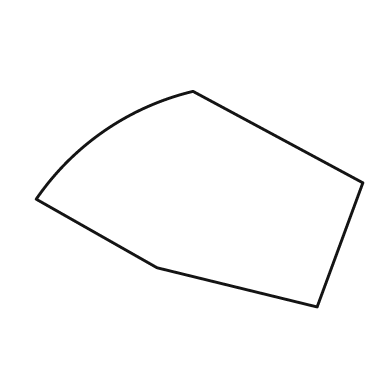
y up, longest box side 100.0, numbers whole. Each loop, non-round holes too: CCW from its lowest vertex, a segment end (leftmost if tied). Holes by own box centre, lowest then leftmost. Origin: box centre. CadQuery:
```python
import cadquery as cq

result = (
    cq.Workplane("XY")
    .moveTo(36.0, -33.0)
    .lineTo(50.0, 5.0)
    .lineTo(-2.0, 33.0)
    .threePointArc((-29.0, 21.0), (-50.0, 0.0))
    .lineTo(-13.0, -21.0)
    .close()
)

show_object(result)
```